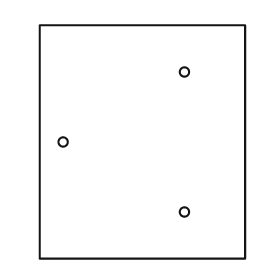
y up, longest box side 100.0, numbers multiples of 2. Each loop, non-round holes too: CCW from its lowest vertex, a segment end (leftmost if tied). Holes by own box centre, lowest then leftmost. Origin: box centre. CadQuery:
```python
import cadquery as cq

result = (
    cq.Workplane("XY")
    .moveTo(-44.0, -50.0)
    .lineTo(44.0, -50.0)
    .lineTo(44.0, 50.0)
    .lineTo(-44.0, 50.0)
    .close()
    .moveTo(18.0, -30.0)
    .circle(2.0)
    .moveTo(-34.0, 0.0)
    .circle(2.0)
    .moveTo(18.0, 30.0)
    .circle(2.0)
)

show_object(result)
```